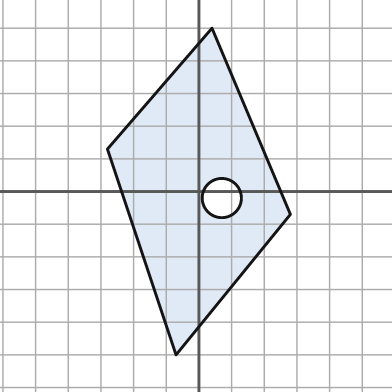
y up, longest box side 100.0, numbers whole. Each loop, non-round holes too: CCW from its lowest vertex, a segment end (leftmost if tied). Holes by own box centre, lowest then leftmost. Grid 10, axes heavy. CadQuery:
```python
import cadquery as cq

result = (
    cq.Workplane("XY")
    .moveTo(-7.0, -50.0)
    .lineTo(28.0, -7.0)
    .lineTo(4.0, 50.0)
    .lineTo(-28.0, 13.0)
    .close()
    .moveTo(7.0, -2.0)
    .circle(6.0)
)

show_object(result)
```